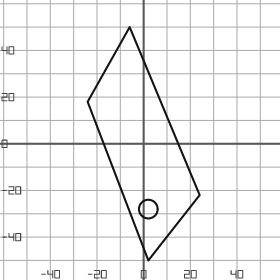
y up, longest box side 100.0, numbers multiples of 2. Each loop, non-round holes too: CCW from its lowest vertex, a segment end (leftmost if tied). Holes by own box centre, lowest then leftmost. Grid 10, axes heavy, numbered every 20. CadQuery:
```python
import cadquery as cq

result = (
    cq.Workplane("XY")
    .moveTo(2.0, -50.0)
    .lineTo(24.0, -22.0)
    .lineTo(-6.0, 50.0)
    .lineTo(-24.0, 18.0)
    .close()
    .moveTo(2.0, -28.0)
    .circle(4.0)
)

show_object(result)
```